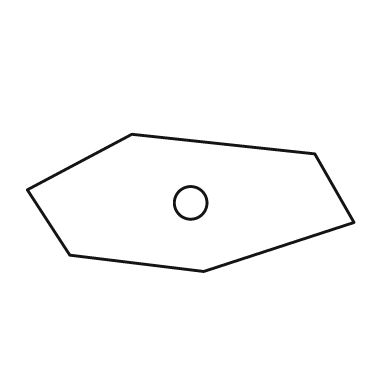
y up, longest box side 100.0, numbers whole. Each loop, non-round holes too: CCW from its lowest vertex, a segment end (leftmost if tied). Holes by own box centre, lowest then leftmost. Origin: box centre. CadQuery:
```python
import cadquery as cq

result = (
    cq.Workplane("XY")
    .moveTo(4.0, -21.0)
    .lineTo(50.0, -6.0)
    .lineTo(38.0, 15.0)
    .lineTo(-18.0, 21.0)
    .lineTo(-50.0, 4.0)
    .lineTo(-37.0, -16.0)
    .close()
    .moveTo(0.0, 0.0)
    .circle(5.0)
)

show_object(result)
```